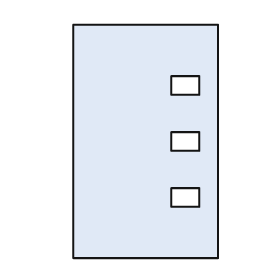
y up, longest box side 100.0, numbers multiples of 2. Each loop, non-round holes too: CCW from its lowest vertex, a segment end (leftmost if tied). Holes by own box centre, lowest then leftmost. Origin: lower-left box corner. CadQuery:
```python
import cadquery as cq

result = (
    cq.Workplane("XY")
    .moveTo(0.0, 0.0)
    .lineTo(62.0, 0.0)
    .lineTo(62.0, 100.0)
    .lineTo(0.0, 100.0)
    .close()
    .moveTo(42.0, 22.0)
    .lineTo(54.0, 22.0)
    .lineTo(54.0, 30.0)
    .lineTo(42.0, 30.0)
    .close()
    .moveTo(42.0, 46.0)
    .lineTo(54.0, 46.0)
    .lineTo(54.0, 54.0)
    .lineTo(42.0, 54.0)
    .close()
    .moveTo(42.0, 70.0)
    .lineTo(54.0, 70.0)
    .lineTo(54.0, 78.0)
    .lineTo(42.0, 78.0)
    .close()
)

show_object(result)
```